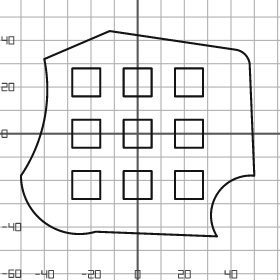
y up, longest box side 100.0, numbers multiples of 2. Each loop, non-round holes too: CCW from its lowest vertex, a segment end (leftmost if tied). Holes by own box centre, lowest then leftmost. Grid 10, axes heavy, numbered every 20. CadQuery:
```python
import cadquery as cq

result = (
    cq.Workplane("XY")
    .moveTo(34.0, -44.0)
    .threePointArc((34.0, -26.0), (50.0, -18.0))
    .lineTo(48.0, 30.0)
    .threePointArc((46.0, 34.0), (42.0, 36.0))
    .lineTo(-12.0, 44.0)
    .lineTo(-40.0, 32.0)
    .threePointArc((-40.0, 6.0), (-50.0, -18.0))
    .threePointArc((-40.0, -38.0), (-18.0, -42.0))
    .close()
    .moveTo(-28.0, -28.0)
    .lineTo(-16.0, -28.0)
    .lineTo(-16.0, -16.0)
    .lineTo(-28.0, -16.0)
    .close()
    .moveTo(-6.0, -28.0)
    .lineTo(6.0, -28.0)
    .lineTo(6.0, -16.0)
    .lineTo(-6.0, -16.0)
    .close()
    .moveTo(16.0, -28.0)
    .lineTo(28.0, -28.0)
    .lineTo(28.0, -16.0)
    .lineTo(16.0, -16.0)
    .close()
    .moveTo(-28.0, -6.0)
    .lineTo(-16.0, -6.0)
    .lineTo(-16.0, 6.0)
    .lineTo(-28.0, 6.0)
    .close()
    .moveTo(-6.0, -6.0)
    .lineTo(6.0, -6.0)
    .lineTo(6.0, 6.0)
    .lineTo(-6.0, 6.0)
    .close()
    .moveTo(16.0, -6.0)
    .lineTo(28.0, -6.0)
    .lineTo(28.0, 6.0)
    .lineTo(16.0, 6.0)
    .close()
    .moveTo(-28.0, 16.0)
    .lineTo(-16.0, 16.0)
    .lineTo(-16.0, 28.0)
    .lineTo(-28.0, 28.0)
    .close()
    .moveTo(-6.0, 16.0)
    .lineTo(6.0, 16.0)
    .lineTo(6.0, 28.0)
    .lineTo(-6.0, 28.0)
    .close()
    .moveTo(16.0, 16.0)
    .lineTo(28.0, 16.0)
    .lineTo(28.0, 28.0)
    .lineTo(16.0, 28.0)
    .close()
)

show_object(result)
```